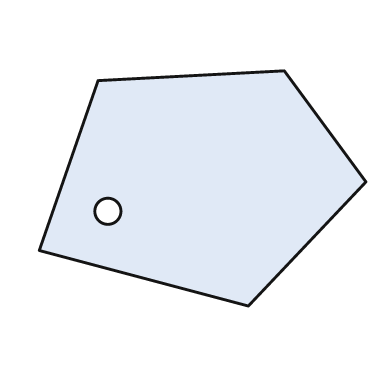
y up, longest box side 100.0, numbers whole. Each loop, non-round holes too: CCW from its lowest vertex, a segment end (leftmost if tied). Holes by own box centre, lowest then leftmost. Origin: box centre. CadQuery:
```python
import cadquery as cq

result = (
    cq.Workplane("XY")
    .moveTo(14.0, -36.0)
    .lineTo(50.0, 2.0)
    .lineTo(25.0, 36.0)
    .lineTo(-32.0, 33.0)
    .lineTo(-50.0, -19.0)
    .close()
    .moveTo(-29.0, -7.0)
    .circle(4.0)
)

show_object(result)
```